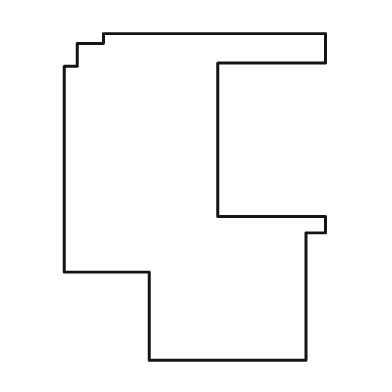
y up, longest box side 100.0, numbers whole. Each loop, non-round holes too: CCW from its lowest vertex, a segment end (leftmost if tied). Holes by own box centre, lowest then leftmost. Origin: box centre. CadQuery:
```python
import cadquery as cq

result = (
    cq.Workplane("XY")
    .moveTo(-14.0, -50.0)
    .lineTo(34.0, -50.0)
    .lineTo(34.0, -11.0)
    .lineTo(40.0, -11.0)
    .lineTo(40.0, -6.0)
    .lineTo(7.0, -6.0)
    .lineTo(7.0, 41.0)
    .lineTo(40.0, 41.0)
    .lineTo(40.0, 50.0)
    .lineTo(-28.0, 50.0)
    .lineTo(-28.0, 47.0)
    .lineTo(-36.0, 47.0)
    .lineTo(-36.0, 40.0)
    .lineTo(-40.0, 40.0)
    .lineTo(-40.0, -23.0)
    .lineTo(-14.0, -23.0)
    .close()
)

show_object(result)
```